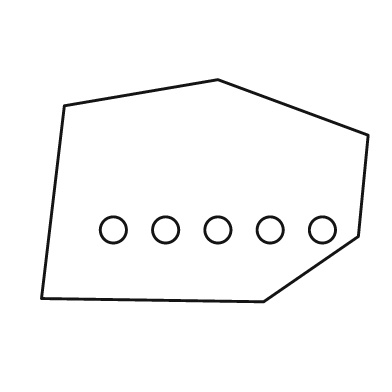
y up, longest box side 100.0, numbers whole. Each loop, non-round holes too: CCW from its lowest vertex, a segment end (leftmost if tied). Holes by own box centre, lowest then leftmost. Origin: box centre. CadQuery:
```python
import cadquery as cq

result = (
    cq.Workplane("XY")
    .moveTo(18.0, -34.0)
    .lineTo(47.0, -14.0)
    .lineTo(50.0, 17.0)
    .lineTo(4.0, 34.0)
    .lineTo(-43.0, 26.0)
    .lineTo(-50.0, -33.0)
    .close()
    .moveTo(-28.0, -12.0)
    .circle(4.0)
    .moveTo(-12.0, -12.0)
    .circle(4.0)
    .moveTo(4.0, -12.0)
    .circle(4.0)
    .moveTo(20.0, -12.0)
    .circle(4.0)
    .moveTo(36.0, -12.0)
    .circle(4.0)
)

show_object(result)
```